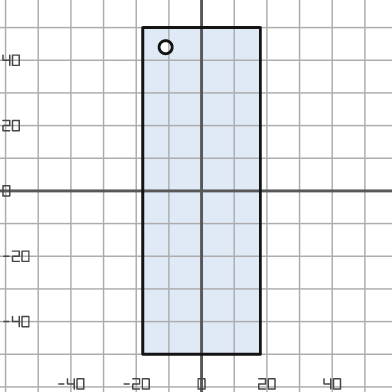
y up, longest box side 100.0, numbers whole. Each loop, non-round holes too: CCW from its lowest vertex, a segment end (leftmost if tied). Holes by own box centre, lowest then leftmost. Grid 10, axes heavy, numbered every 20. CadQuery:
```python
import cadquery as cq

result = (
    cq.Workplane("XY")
    .moveTo(-18.0, -50.0)
    .lineTo(18.0, -50.0)
    .lineTo(18.0, 50.0)
    .lineTo(-18.0, 50.0)
    .close()
    .moveTo(-11.0, 44.0)
    .circle(2.0)
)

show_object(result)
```